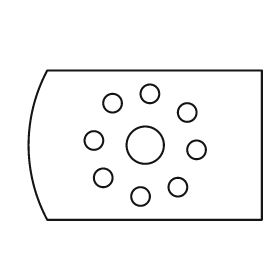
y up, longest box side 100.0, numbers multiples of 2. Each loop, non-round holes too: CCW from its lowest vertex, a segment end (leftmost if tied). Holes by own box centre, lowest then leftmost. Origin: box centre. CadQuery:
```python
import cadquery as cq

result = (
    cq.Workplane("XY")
    .moveTo(-42.0, -32.0)
    .lineTo(50.0, -32.0)
    .lineTo(50.0, 32.0)
    .lineTo(-42.0, 32.0)
    .threePointArc((-50.0, 0.0), (-42.0, -32.0))
    .close()
    .moveTo(-2.0, -22.0)
    .circle(4.0)
    .moveTo(14.0, -18.0)
    .circle(4.0)
    .moveTo(-18.0, -14.0)
    .circle(4.0)
    .moveTo(22.0, -2.0)
    .circle(4.0)
    .moveTo(0.0, 0.0)
    .circle(8.0)
    .moveTo(-22.0, 2.0)
    .circle(4.0)
    .moveTo(18.0, 14.0)
    .circle(4.0)
    .moveTo(-14.0, 18.0)
    .circle(4.0)
    .moveTo(2.0, 22.0)
    .circle(4.0)
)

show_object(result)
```